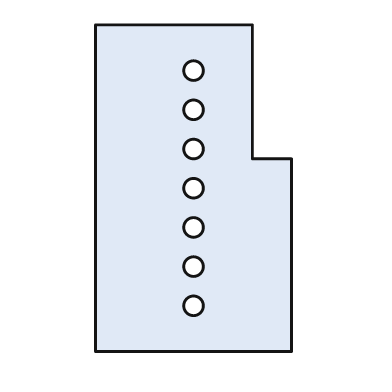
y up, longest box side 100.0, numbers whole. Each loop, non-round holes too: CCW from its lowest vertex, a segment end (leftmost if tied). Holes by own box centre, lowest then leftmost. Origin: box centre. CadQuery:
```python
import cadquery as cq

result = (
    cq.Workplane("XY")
    .moveTo(-30.0, -50.0)
    .lineTo(30.0, -50.0)
    .lineTo(30.0, 9.0)
    .lineTo(18.0, 9.0)
    .lineTo(18.0, 50.0)
    .lineTo(-30.0, 50.0)
    .close()
    .moveTo(0.0, -36.0)
    .circle(3.0)
    .moveTo(0.0, -24.0)
    .circle(3.0)
    .moveTo(0.0, -12.0)
    .circle(3.0)
    .moveTo(0.0, 0.0)
    .circle(3.0)
    .moveTo(0.0, 12.0)
    .circle(3.0)
    .moveTo(0.0, 24.0)
    .circle(3.0)
    .moveTo(0.0, 36.0)
    .circle(3.0)
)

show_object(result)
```